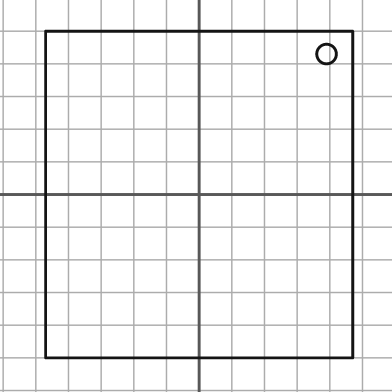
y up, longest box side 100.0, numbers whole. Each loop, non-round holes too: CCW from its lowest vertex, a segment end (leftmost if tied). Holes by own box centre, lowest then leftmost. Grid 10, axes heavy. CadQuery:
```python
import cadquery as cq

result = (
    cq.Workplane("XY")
    .moveTo(-47.0, -50.0)
    .lineTo(47.0, -50.0)
    .lineTo(47.0, 50.0)
    .lineTo(-47.0, 50.0)
    .close()
    .moveTo(39.0, 43.0)
    .circle(3.0)
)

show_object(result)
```